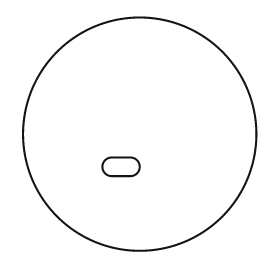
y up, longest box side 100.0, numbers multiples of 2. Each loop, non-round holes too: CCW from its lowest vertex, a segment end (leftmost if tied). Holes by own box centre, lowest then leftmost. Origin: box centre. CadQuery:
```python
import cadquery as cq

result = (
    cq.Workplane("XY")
    .moveTo(0.0, 0.0)
    .circle(50.0)
    .moveTo(-12.0, -18.0)
    .lineTo(-4.0, -18.0)
    .threePointArc((0.0, -14.0), (-4.0, -10.0))
    .lineTo(-12.0, -10.0)
    .threePointArc((-16.0, -14.0), (-12.0, -18.0))
    .close()
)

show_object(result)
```